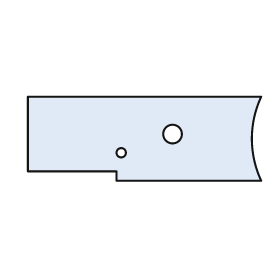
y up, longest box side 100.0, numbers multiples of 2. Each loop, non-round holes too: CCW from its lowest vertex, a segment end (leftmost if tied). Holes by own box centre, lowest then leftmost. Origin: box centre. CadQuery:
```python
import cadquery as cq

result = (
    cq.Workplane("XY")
    .moveTo(-12.0, -18.0)
    .lineTo(50.0, -18.0)
    .threePointArc((46.0, 0.0), (50.0, 18.0))
    .lineTo(-50.0, 18.0)
    .lineTo(-50.0, -14.0)
    .lineTo(-12.0, -14.0)
    .close()
    .moveTo(-10.0, -6.0)
    .circle(2.0)
    .moveTo(12.0, 2.0)
    .circle(4.0)
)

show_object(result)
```